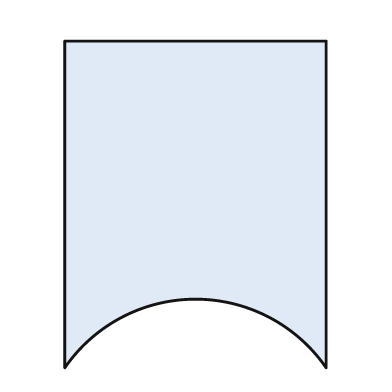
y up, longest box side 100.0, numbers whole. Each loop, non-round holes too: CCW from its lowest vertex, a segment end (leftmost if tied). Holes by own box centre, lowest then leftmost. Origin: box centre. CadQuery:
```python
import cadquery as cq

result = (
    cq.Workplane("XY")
    .moveTo(-40.0, -50.0)
    .threePointArc((0.0, -29.0), (40.0, -50.0))
    .lineTo(40.0, 50.0)
    .lineTo(-40.0, 50.0)
    .close()
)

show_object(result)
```